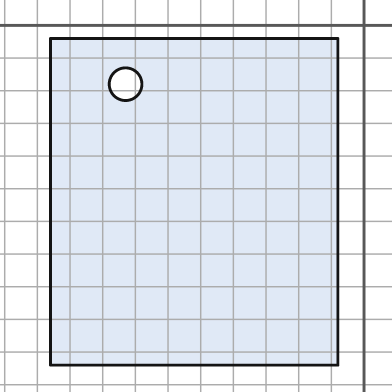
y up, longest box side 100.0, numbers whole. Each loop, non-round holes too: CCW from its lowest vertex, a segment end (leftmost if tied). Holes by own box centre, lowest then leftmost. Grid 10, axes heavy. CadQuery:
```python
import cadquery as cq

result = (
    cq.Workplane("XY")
    .moveTo(-96.0, -104.0)
    .lineTo(-8.0, -104.0)
    .lineTo(-8.0, -4.0)
    .lineTo(-96.0, -4.0)
    .close()
    .moveTo(-73.0, -18.0)
    .circle(5.0)
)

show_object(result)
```